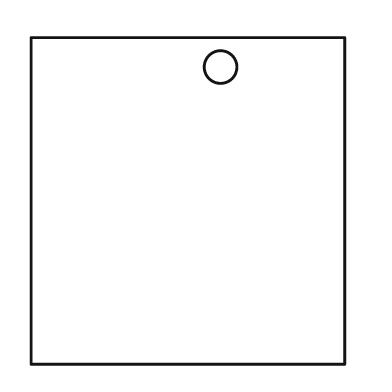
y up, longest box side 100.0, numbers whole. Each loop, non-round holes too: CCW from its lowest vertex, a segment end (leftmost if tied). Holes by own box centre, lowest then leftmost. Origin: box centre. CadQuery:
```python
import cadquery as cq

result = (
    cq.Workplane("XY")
    .moveTo(-48.0, -50.0)
    .lineTo(48.0, -50.0)
    .lineTo(48.0, 50.0)
    .lineTo(-48.0, 50.0)
    .close()
    .moveTo(10.0, 41.0)
    .circle(5.0)
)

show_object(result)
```